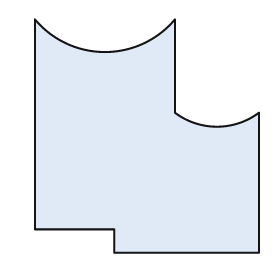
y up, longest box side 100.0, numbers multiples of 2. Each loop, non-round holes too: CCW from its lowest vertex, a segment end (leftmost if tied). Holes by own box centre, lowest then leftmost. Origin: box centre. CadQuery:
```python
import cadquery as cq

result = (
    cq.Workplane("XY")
    .moveTo(-14.0, -50.0)
    .lineTo(48.0, -50.0)
    .lineTo(48.0, 10.0)
    .threePointArc((30.0, 4.0), (12.0, 10.0))
    .lineTo(12.0, 50.0)
    .threePointArc((-18.0, 36.0), (-48.0, 50.0))
    .lineTo(-48.0, -40.0)
    .lineTo(-14.0, -40.0)
    .close()
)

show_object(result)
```